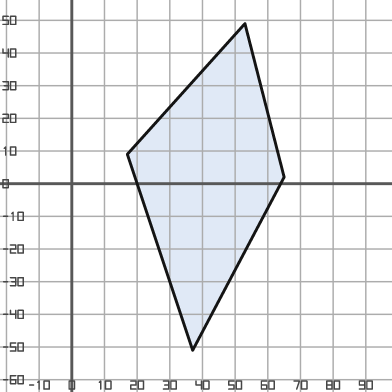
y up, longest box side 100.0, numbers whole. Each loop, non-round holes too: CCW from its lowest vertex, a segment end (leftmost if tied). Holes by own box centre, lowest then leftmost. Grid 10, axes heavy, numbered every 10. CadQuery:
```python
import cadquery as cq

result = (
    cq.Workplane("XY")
    .moveTo(37.0, -51.0)
    .lineTo(65.0, 2.0)
    .lineTo(53.0, 49.0)
    .lineTo(17.0, 9.0)
    .close()
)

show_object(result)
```